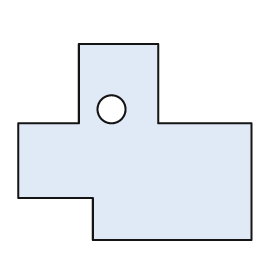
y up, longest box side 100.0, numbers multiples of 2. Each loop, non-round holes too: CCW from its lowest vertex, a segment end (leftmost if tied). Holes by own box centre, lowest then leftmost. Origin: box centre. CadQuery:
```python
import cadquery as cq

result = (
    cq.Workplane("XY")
    .moveTo(-18.0, -42.0)
    .lineTo(50.0, -42.0)
    .lineTo(50.0, 8.0)
    .lineTo(10.0, 8.0)
    .lineTo(10.0, 42.0)
    .lineTo(-24.0, 42.0)
    .lineTo(-24.0, 8.0)
    .lineTo(-50.0, 8.0)
    .lineTo(-50.0, -24.0)
    .lineTo(-18.0, -24.0)
    .close()
    .moveTo(-10.0, 14.0)
    .circle(6.0)
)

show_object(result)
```